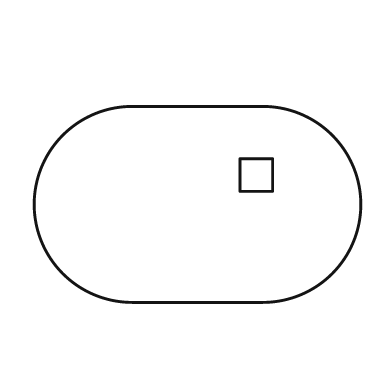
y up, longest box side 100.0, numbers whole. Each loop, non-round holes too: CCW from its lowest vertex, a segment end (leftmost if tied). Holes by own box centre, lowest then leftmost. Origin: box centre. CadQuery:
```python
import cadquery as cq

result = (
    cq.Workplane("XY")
    .moveTo(-20.0, -30.0)
    .lineTo(20.0, -30.0)
    .threePointArc((50.0, 0.0), (20.0, 30.0))
    .lineTo(-20.0, 30.0)
    .threePointArc((-50.0, 0.0), (-20.0, -30.0))
    .close()
    .moveTo(13.0, 4.0)
    .lineTo(23.0, 4.0)
    .lineTo(23.0, 14.0)
    .lineTo(13.0, 14.0)
    .close()
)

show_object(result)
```